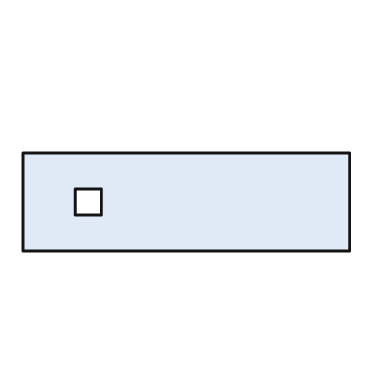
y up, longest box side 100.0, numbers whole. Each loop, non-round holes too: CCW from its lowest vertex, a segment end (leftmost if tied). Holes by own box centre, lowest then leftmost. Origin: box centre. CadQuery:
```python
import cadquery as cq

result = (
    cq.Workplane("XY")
    .moveTo(-50.0, -15.0)
    .lineTo(50.0, -15.0)
    .lineTo(50.0, 15.0)
    .lineTo(-50.0, 15.0)
    .close()
    .moveTo(-34.0, -4.0)
    .lineTo(-26.0, -4.0)
    .lineTo(-26.0, 4.0)
    .lineTo(-34.0, 4.0)
    .close()
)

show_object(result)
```